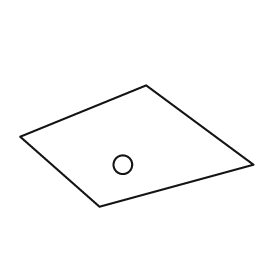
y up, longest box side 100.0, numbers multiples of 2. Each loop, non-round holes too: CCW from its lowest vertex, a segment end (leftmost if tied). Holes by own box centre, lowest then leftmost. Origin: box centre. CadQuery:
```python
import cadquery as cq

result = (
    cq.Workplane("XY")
    .moveTo(-16.0, -26.0)
    .lineTo(50.0, -8.0)
    .lineTo(4.0, 26.0)
    .lineTo(-50.0, 4.0)
    .close()
    .moveTo(-6.0, -8.0)
    .circle(4.0)
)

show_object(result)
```